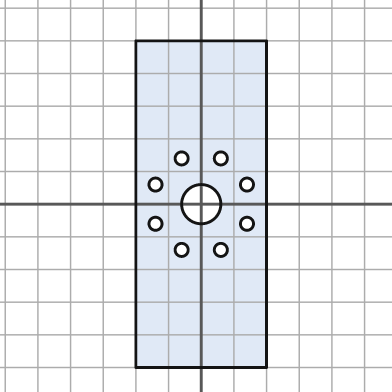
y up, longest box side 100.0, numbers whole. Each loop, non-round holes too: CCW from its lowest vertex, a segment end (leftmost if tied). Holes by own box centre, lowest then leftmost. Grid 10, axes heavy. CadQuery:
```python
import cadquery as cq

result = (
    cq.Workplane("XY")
    .moveTo(-20.0, -50.0)
    .lineTo(20.0, -50.0)
    .lineTo(20.0, 50.0)
    .lineTo(-20.0, 50.0)
    .close()
    .moveTo(-6.0, -14.0)
    .circle(2.0)
    .moveTo(6.0, -14.0)
    .circle(2.0)
    .moveTo(-14.0, -6.0)
    .circle(2.0)
    .moveTo(14.0, -6.0)
    .circle(2.0)
    .moveTo(0.0, 0.0)
    .circle(6.0)
    .moveTo(-14.0, 6.0)
    .circle(2.0)
    .moveTo(14.0, 6.0)
    .circle(2.0)
    .moveTo(-6.0, 14.0)
    .circle(2.0)
    .moveTo(6.0, 14.0)
    .circle(2.0)
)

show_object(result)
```